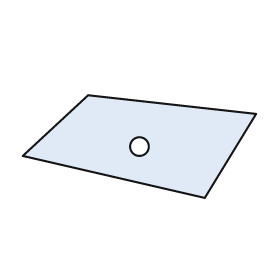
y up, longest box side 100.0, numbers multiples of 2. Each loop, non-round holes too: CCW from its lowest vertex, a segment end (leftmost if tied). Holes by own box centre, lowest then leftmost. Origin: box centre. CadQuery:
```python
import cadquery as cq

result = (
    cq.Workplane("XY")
    .moveTo(28.0, -22.0)
    .lineTo(50.0, 14.0)
    .lineTo(-22.0, 22.0)
    .lineTo(-50.0, -4.0)
    .close()
    .moveTo(0.0, 0.0)
    .circle(4.0)
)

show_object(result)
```